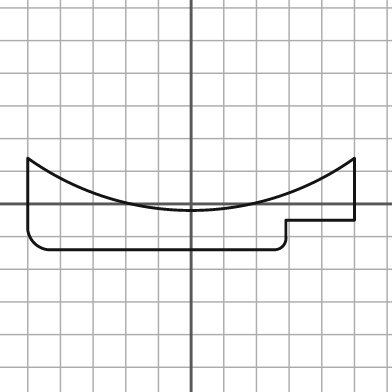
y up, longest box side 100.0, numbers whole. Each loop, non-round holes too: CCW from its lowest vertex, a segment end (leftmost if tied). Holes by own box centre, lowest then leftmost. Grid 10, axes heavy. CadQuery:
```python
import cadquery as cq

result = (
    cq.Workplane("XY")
    .moveTo(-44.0, -14.0)
    .lineTo(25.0, -14.0)
    .threePointArc((28.0, -13.0), (29.0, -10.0))
    .lineTo(29.0, -5.0)
    .lineTo(50.0, -5.0)
    .lineTo(50.0, 14.0)
    .threePointArc((0.0, -2.0), (-50.0, 14.0))
    .lineTo(-50.0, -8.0)
    .threePointArc((-48.0, -12.0), (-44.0, -14.0))
    .close()
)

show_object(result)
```